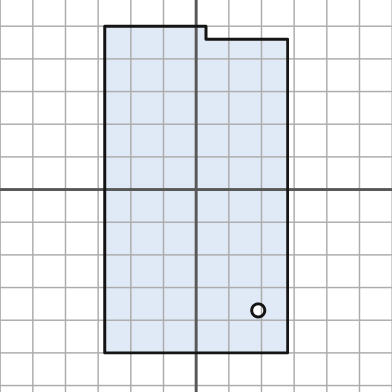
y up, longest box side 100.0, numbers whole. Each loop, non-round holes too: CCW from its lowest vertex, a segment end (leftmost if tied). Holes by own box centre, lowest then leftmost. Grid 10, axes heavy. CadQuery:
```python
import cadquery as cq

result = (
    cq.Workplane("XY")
    .moveTo(-28.0, -50.0)
    .lineTo(28.0, -50.0)
    .lineTo(28.0, 46.0)
    .lineTo(3.0, 46.0)
    .lineTo(3.0, 50.0)
    .lineTo(-28.0, 50.0)
    .close()
    .moveTo(19.0, -37.0)
    .circle(2.0)
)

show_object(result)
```